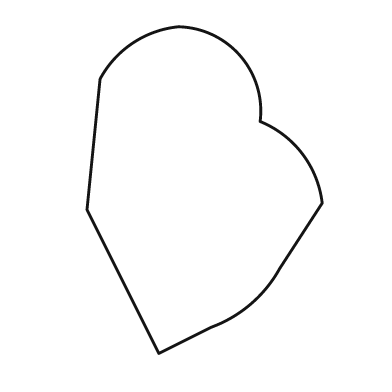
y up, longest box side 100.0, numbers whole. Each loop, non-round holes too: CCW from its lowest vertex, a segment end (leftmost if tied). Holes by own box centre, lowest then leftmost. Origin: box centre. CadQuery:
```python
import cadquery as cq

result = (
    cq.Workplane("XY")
    .moveTo(-14.0, -50.0)
    .lineTo(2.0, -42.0)
    .threePointArc((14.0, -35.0), (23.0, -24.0))
    .lineTo(36.0, -4.0)
    .threePointArc((30.0, 11.0), (17.0, 21.0))
    .threePointArc((11.0, 41.0), (-8.0, 50.0))
    .threePointArc((-22.0, 45.0), (-32.0, 34.0))
    .lineTo(-36.0, -6.0)
    .close()
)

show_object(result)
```